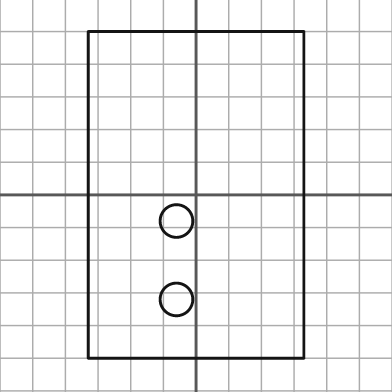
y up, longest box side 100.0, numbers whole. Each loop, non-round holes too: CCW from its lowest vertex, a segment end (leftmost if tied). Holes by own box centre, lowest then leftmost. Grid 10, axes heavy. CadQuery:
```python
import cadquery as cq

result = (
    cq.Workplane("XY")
    .moveTo(-33.0, -50.0)
    .lineTo(33.0, -50.0)
    .lineTo(33.0, 50.0)
    .lineTo(-33.0, 50.0)
    .close()
    .moveTo(-6.0, -32.0)
    .circle(5.0)
    .moveTo(-6.0, -8.0)
    .circle(5.0)
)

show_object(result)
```